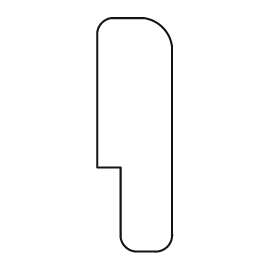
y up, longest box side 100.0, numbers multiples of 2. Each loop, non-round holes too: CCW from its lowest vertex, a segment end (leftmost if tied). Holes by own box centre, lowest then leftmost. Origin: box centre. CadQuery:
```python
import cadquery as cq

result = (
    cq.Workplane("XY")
    .moveTo(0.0, -50.0)
    .lineTo(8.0, -50.0)
    .threePointArc((14.0, -48.0), (16.0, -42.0))
    .lineTo(16.0, 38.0)
    .threePointArc((12.0, 46.0), (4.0, 50.0))
    .lineTo(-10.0, 50.0)
    .threePointArc((-14.0, 48.0), (-16.0, 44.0))
    .lineTo(-16.0, -14.0)
    .lineTo(-6.0, -14.0)
    .lineTo(-6.0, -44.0)
    .threePointArc((-4.0, -48.0), (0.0, -50.0))
    .close()
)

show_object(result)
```